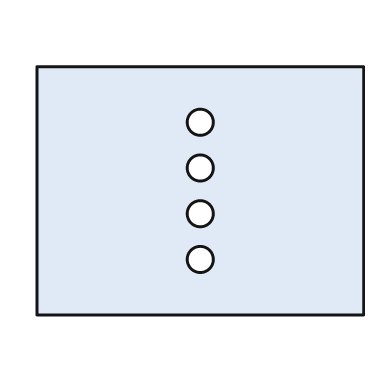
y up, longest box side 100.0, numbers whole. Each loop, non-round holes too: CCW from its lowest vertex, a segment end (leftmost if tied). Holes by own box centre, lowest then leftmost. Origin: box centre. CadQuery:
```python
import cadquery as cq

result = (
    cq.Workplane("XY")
    .moveTo(-50.0, -38.0)
    .lineTo(50.0, -38.0)
    .lineTo(50.0, 38.0)
    .lineTo(-50.0, 38.0)
    .close()
    .moveTo(0.0, -21.0)
    .circle(4.0)
    .moveTo(0.0, -7.0)
    .circle(4.0)
    .moveTo(0.0, 7.0)
    .circle(4.0)
    .moveTo(0.0, 21.0)
    .circle(4.0)
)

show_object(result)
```